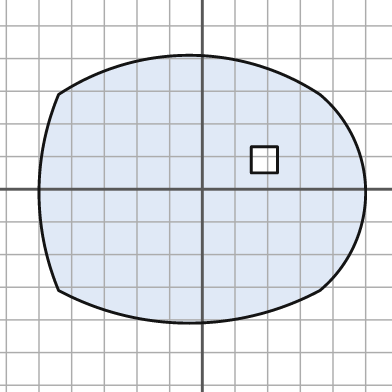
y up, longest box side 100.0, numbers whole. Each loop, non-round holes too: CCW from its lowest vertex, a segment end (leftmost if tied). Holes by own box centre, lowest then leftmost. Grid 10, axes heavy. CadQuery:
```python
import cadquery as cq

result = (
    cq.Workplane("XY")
    .moveTo(-44.0, -31.0)
    .threePointArc((-4.0, -41.0), (36.0, -31.0))
    .threePointArc((50.0, -1.0), (36.0, 29.0))
    .threePointArc((-4.0, 41.0), (-44.0, 29.0))
    .threePointArc((-50.0, -1.0), (-44.0, -31.0))
    .close()
    .moveTo(15.0, 5.0)
    .lineTo(23.0, 5.0)
    .lineTo(23.0, 13.0)
    .lineTo(15.0, 13.0)
    .close()
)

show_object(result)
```